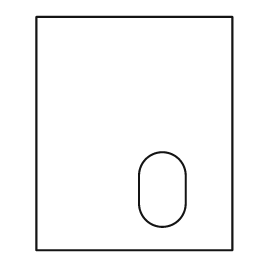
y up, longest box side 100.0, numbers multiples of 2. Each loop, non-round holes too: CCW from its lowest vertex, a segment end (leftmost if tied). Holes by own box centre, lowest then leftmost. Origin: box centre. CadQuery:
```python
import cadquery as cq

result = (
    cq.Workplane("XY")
    .moveTo(-42.0, -50.0)
    .lineTo(42.0, -50.0)
    .lineTo(42.0, 50.0)
    .lineTo(-42.0, 50.0)
    .close()
    .moveTo(2.0, -30.0)
    .threePointArc((12.0, -40.0), (22.0, -30.0))
    .lineTo(22.0, -18.0)
    .threePointArc((12.0, -8.0), (2.0, -18.0))
    .close()
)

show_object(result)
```